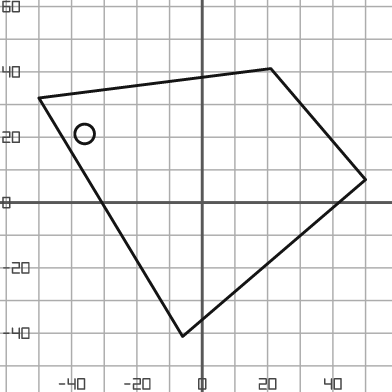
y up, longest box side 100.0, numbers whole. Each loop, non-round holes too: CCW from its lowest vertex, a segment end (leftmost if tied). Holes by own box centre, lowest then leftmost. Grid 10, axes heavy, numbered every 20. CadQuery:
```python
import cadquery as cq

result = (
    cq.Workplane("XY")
    .moveTo(-6.0, -41.0)
    .lineTo(50.0, 7.0)
    .lineTo(21.0, 41.0)
    .lineTo(-50.0, 32.0)
    .close()
    .moveTo(-36.0, 21.0)
    .circle(3.0)
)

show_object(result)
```